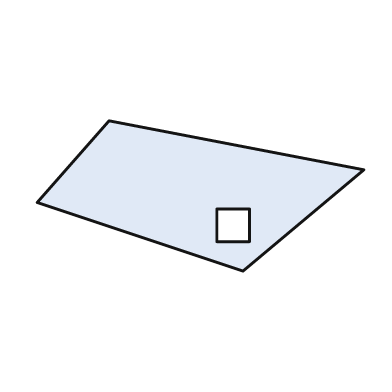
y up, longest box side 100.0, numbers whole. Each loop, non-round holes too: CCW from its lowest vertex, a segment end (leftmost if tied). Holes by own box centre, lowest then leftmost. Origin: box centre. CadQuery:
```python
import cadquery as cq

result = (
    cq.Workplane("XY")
    .moveTo(13.0, -23.0)
    .lineTo(50.0, 8.0)
    .lineTo(-28.0, 23.0)
    .lineTo(-50.0, -2.0)
    .close()
    .moveTo(5.0, -14.0)
    .lineTo(15.0, -14.0)
    .lineTo(15.0, -4.0)
    .lineTo(5.0, -4.0)
    .close()
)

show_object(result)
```